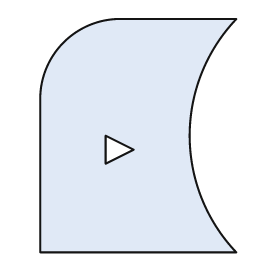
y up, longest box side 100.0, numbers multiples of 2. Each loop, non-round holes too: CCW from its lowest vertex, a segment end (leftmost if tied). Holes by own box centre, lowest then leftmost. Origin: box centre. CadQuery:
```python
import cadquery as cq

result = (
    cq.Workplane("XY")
    .moveTo(-42.0, -50.0)
    .lineTo(42.0, -50.0)
    .threePointArc((22.0, 0.0), (42.0, 50.0))
    .lineTo(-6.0, 50.0)
    .threePointArc((-32.0, 40.0), (-42.0, 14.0))
    .close()
    .moveTo(-14.0, -12.0)
    .lineTo(-2.0, -6.0)
    .lineTo(-14.0, 0.0)
    .close()
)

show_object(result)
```